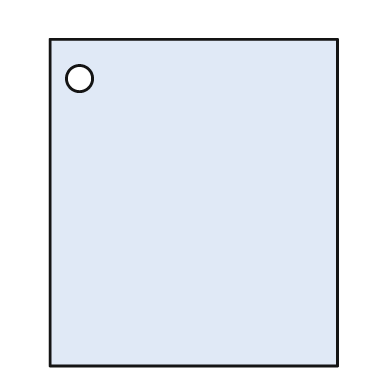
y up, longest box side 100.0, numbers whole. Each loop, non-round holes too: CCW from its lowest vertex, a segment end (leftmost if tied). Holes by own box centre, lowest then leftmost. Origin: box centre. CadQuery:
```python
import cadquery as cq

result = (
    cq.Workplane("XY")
    .moveTo(-44.0, -50.0)
    .lineTo(44.0, -50.0)
    .lineTo(44.0, 50.0)
    .lineTo(-44.0, 50.0)
    .close()
    .moveTo(-35.0, 38.0)
    .circle(4.0)
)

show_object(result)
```